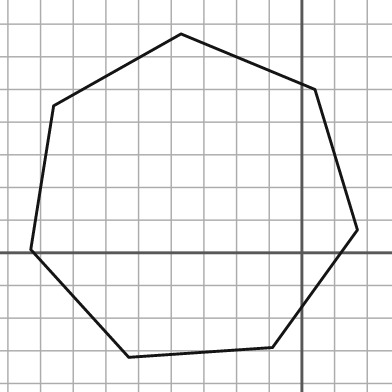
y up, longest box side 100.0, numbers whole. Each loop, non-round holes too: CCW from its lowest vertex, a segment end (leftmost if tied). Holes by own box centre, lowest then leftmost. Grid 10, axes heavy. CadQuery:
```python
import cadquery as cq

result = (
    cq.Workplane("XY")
    .moveTo(-53.0, -32.0)
    .lineTo(-9.0, -29.0)
    .lineTo(17.0, 7.0)
    .lineTo(4.0, 50.0)
    .lineTo(-37.0, 67.0)
    .lineTo(-76.0, 45.0)
    .lineTo(-83.0, 1.0)
    .close()
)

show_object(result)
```